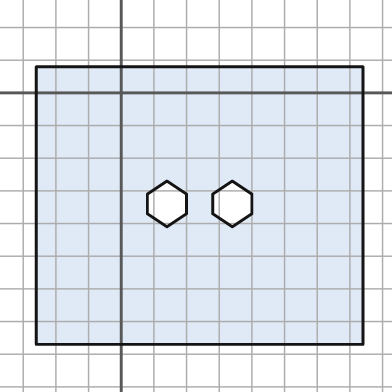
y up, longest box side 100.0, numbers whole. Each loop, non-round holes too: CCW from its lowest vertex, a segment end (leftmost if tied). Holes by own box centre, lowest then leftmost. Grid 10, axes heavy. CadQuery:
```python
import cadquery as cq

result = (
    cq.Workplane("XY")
    .moveTo(-26.0, -77.0)
    .lineTo(74.0, -77.0)
    .lineTo(74.0, 8.0)
    .lineTo(-26.0, 8.0)
    .close()
    .moveTo(14.0, -41.0)
    .lineTo(20.0, -37.0)
    .lineTo(20.0, -31.0)
    .lineTo(14.0, -27.0)
    .lineTo(8.0, -31.0)
    .lineTo(8.0, -37.0)
    .close()
    .moveTo(34.0, -41.0)
    .lineTo(40.0, -37.0)
    .lineTo(40.0, -31.0)
    .lineTo(34.0, -27.0)
    .lineTo(28.0, -31.0)
    .lineTo(28.0, -37.0)
    .close()
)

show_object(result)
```